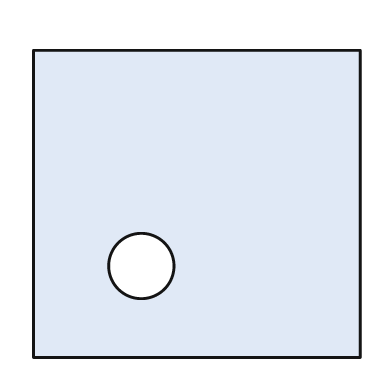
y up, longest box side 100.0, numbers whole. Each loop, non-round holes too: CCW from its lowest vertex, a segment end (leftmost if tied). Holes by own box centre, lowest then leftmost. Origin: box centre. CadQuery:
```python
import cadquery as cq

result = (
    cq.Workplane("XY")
    .moveTo(-50.0, -47.0)
    .lineTo(50.0, -47.0)
    .lineTo(50.0, 47.0)
    .lineTo(-50.0, 47.0)
    .close()
    .moveTo(-17.0, -19.0)
    .circle(10.0)
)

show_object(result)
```